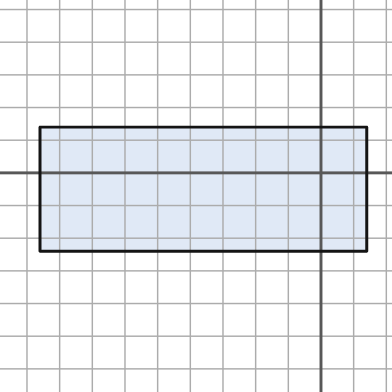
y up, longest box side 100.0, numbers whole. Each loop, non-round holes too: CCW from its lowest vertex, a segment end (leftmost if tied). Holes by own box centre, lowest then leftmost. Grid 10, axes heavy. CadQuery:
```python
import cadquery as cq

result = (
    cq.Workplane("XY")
    .moveTo(-86.0, -24.0)
    .lineTo(14.0, -24.0)
    .lineTo(14.0, 14.0)
    .lineTo(-86.0, 14.0)
    .close()
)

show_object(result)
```